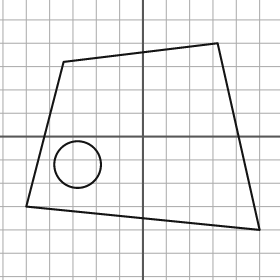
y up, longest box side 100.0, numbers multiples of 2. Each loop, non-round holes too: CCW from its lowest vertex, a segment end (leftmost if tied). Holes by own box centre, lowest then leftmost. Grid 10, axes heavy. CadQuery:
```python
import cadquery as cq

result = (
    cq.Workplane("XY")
    .moveTo(50.0, -40.0)
    .lineTo(32.0, 40.0)
    .lineTo(-34.0, 32.0)
    .lineTo(-50.0, -30.0)
    .close()
    .moveTo(-28.0, -12.0)
    .circle(10.0)
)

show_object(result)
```